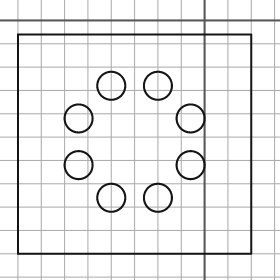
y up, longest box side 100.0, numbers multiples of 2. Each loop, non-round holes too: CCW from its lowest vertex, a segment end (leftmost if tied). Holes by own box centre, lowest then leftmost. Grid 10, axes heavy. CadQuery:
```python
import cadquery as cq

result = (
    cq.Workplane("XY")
    .moveTo(-80.0, -100.0)
    .lineTo(20.0, -100.0)
    .lineTo(20.0, -6.0)
    .lineTo(-80.0, -6.0)
    .close()
    .moveTo(-40.0, -76.0)
    .circle(6.0)
    .moveTo(-20.0, -76.0)
    .circle(6.0)
    .moveTo(-54.0, -62.0)
    .circle(6.0)
    .moveTo(-6.0, -62.0)
    .circle(6.0)
    .moveTo(-54.0, -42.0)
    .circle(6.0)
    .moveTo(-6.0, -42.0)
    .circle(6.0)
    .moveTo(-40.0, -28.0)
    .circle(6.0)
    .moveTo(-20.0, -28.0)
    .circle(6.0)
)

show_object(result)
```